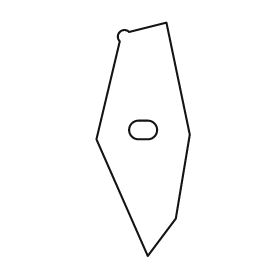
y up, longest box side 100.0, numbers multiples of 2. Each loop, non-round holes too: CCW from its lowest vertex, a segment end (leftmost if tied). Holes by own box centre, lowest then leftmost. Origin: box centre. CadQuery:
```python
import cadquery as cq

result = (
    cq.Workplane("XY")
    .moveTo(2.0, -50.0)
    .lineTo(14.0, -34.0)
    .lineTo(20.0, 2.0)
    .lineTo(10.0, 50.0)
    .lineTo(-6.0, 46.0)
    .threePointArc((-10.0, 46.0), (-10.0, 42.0))
    .lineTo(-20.0, 0.0)
    .close()
    .moveTo(-2.0, 0.0)
    .lineTo(2.0, 0.0)
    .threePointArc((6.0, 4.0), (2.0, 8.0))
    .lineTo(-2.0, 8.0)
    .threePointArc((-6.0, 4.0), (-2.0, 0.0))
    .close()
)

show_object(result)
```